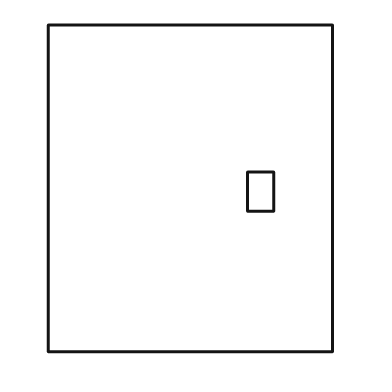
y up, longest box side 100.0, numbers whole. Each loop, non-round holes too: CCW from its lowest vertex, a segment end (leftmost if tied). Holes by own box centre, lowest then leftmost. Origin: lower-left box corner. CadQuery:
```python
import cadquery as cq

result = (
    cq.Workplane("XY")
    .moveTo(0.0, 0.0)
    .lineTo(87.0, 0.0)
    .lineTo(87.0, 100.0)
    .lineTo(0.0, 100.0)
    .close()
    .moveTo(61.0, 43.0)
    .lineTo(69.0, 43.0)
    .lineTo(69.0, 55.0)
    .lineTo(61.0, 55.0)
    .close()
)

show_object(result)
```